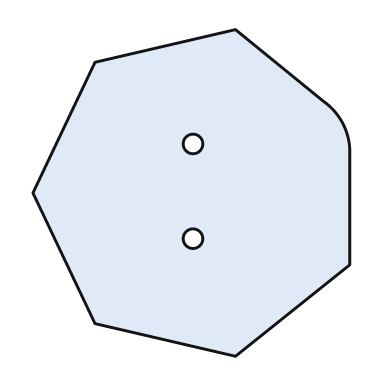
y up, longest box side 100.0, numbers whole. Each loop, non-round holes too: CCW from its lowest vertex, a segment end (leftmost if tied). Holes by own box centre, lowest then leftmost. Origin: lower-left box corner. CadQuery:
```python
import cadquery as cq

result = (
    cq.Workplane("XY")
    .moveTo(62.0, 0.0)
    .lineTo(97.0, 28.0)
    .lineTo(97.0, 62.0)
    .threePointArc((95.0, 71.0), (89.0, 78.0))
    .lineTo(62.0, 100.0)
    .lineTo(19.0, 90.0)
    .lineTo(0.0, 50.0)
    .lineTo(19.0, 10.0)
    .close()
    .moveTo(49.0, 36.0)
    .circle(3.0)
    .moveTo(49.0, 65.0)
    .circle(3.0)
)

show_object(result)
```